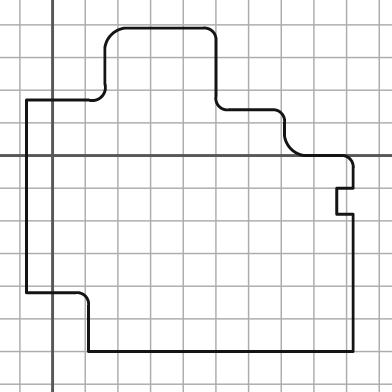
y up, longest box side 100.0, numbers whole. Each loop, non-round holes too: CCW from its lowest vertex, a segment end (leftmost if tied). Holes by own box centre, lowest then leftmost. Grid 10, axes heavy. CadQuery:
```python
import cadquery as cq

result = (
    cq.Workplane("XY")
    .moveTo(11.0, -60.0)
    .lineTo(92.0, -60.0)
    .lineTo(92.0, -18.0)
    .lineTo(87.0, -18.0)
    .lineTo(87.0, -10.0)
    .lineTo(92.0, -10.0)
    .lineTo(92.0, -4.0)
    .threePointArc((91.0, -1.0), (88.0, 0.0))
    .lineTo(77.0, 0.0)
    .threePointArc((73.0, 2.0), (71.0, 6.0))
    .lineTo(71.0, 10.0)
    .threePointArc((70.0, 13.0), (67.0, 14.0))
    .lineTo(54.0, 14.0)
    .threePointArc((51.0, 15.0), (50.0, 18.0))
    .lineTo(50.0, 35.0)
    .threePointArc((49.0, 38.0), (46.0, 39.0))
    .lineTo(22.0, 39.0)
    .threePointArc((18.0, 37.0), (16.0, 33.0))
    .lineTo(16.0, 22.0)
    .threePointArc((15.0, 18.0), (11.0, 17.0))
    .lineTo(-8.0, 17.0)
    .lineTo(-8.0, -42.0)
    .lineTo(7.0, -42.0)
    .threePointArc((10.0, -43.0), (11.0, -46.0))
    .close()
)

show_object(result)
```